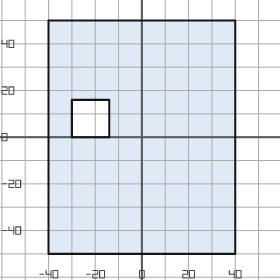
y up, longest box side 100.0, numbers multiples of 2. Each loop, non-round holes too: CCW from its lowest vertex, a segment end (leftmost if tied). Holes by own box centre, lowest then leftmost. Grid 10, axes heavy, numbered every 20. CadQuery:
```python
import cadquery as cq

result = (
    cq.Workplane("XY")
    .moveTo(-40.0, -50.0)
    .lineTo(40.0, -50.0)
    .lineTo(40.0, 50.0)
    .lineTo(-40.0, 50.0)
    .close()
    .moveTo(-30.0, 0.0)
    .lineTo(-14.0, 0.0)
    .lineTo(-14.0, 16.0)
    .lineTo(-30.0, 16.0)
    .close()
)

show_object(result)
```